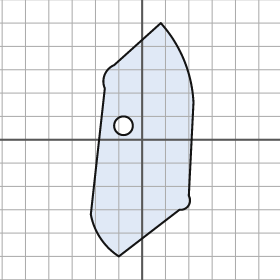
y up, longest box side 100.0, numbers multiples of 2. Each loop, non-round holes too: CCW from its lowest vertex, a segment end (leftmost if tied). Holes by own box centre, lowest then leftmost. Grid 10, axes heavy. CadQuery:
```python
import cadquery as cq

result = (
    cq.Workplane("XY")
    .moveTo(-10.0, -50.0)
    .lineTo(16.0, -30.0)
    .threePointArc((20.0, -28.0), (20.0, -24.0))
    .lineTo(22.0, 16.0)
    .threePointArc((18.0, 34.0), (8.0, 50.0))
    .lineTo(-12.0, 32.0)
    .threePointArc((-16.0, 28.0), (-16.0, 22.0))
    .lineTo(-22.0, -32.0)
    .threePointArc((-18.0, -42.0), (-10.0, -50.0))
    .close()
    .moveTo(-8.0, 6.0)
    .circle(4.0)
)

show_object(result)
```